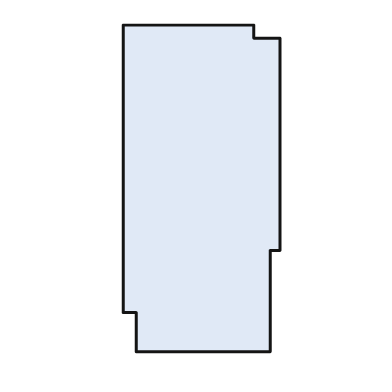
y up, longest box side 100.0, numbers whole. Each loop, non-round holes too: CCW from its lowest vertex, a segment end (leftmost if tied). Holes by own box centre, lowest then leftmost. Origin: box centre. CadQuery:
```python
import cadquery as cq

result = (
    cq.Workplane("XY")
    .moveTo(-20.0, -50.0)
    .lineTo(21.0, -50.0)
    .lineTo(21.0, -19.0)
    .lineTo(24.0, -19.0)
    .lineTo(24.0, 46.0)
    .lineTo(16.0, 46.0)
    .lineTo(16.0, 50.0)
    .lineTo(-24.0, 50.0)
    .lineTo(-24.0, -38.0)
    .lineTo(-20.0, -38.0)
    .close()
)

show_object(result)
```